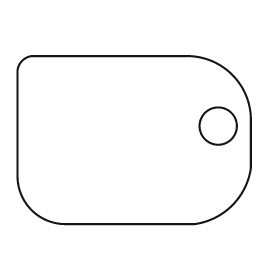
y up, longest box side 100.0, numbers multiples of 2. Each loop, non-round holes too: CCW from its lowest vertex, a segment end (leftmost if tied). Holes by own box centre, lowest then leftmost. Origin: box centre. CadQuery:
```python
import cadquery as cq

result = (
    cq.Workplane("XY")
    .moveTo(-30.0, -36.0)
    .lineTo(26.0, -36.0)
    .threePointArc((42.0, -28.0), (50.0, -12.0))
    .lineTo(50.0, 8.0)
    .threePointArc((42.0, 28.0), (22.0, 36.0))
    .lineTo(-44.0, 36.0)
    .threePointArc((-48.0, 34.0), (-50.0, 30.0))
    .lineTo(-50.0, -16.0)
    .threePointArc((-44.0, -30.0), (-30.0, -36.0))
    .close()
    .moveTo(36.0, 6.0)
    .circle(8.0)
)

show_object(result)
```